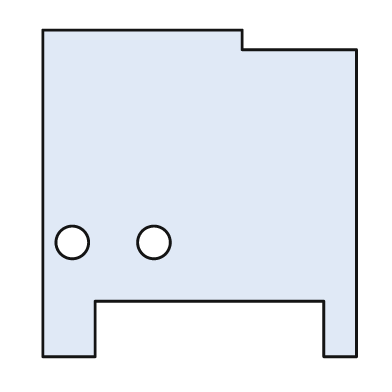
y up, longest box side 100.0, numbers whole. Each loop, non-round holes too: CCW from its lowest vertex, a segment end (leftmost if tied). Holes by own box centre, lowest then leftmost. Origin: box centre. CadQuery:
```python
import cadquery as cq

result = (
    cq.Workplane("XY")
    .moveTo(-48.0, -50.0)
    .lineTo(-32.0, -50.0)
    .lineTo(-32.0, -33.0)
    .lineTo(38.0, -33.0)
    .lineTo(38.0, -50.0)
    .lineTo(48.0, -50.0)
    .lineTo(48.0, 44.0)
    .lineTo(13.0, 44.0)
    .lineTo(13.0, 50.0)
    .lineTo(-48.0, 50.0)
    .close()
    .moveTo(-39.0, -15.0)
    .circle(5.0)
    .moveTo(-14.0, -15.0)
    .circle(5.0)
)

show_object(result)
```